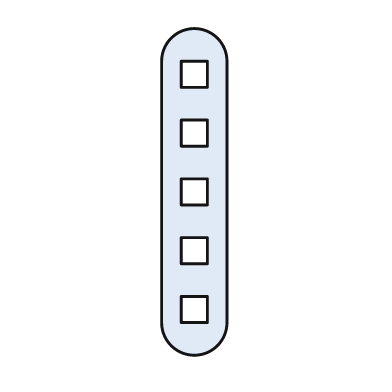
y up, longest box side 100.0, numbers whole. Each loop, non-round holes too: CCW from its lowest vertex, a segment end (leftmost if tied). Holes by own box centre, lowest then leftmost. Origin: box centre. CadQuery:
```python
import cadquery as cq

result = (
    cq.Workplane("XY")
    .moveTo(-10.0, -40.0)
    .threePointArc((0.0, -50.0), (10.0, -40.0))
    .lineTo(10.0, 40.0)
    .threePointArc((0.0, 50.0), (-10.0, 40.0))
    .close()
    .moveTo(-4.0, -40.0)
    .lineTo(4.0, -40.0)
    .lineTo(4.0, -32.0)
    .lineTo(-4.0, -32.0)
    .close()
    .moveTo(-4.0, -22.0)
    .lineTo(4.0, -22.0)
    .lineTo(4.0, -14.0)
    .lineTo(-4.0, -14.0)
    .close()
    .moveTo(-4.0, -4.0)
    .lineTo(4.0, -4.0)
    .lineTo(4.0, 4.0)
    .lineTo(-4.0, 4.0)
    .close()
    .moveTo(-4.0, 14.0)
    .lineTo(4.0, 14.0)
    .lineTo(4.0, 22.0)
    .lineTo(-4.0, 22.0)
    .close()
    .moveTo(-4.0, 32.0)
    .lineTo(4.0, 32.0)
    .lineTo(4.0, 40.0)
    .lineTo(-4.0, 40.0)
    .close()
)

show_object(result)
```